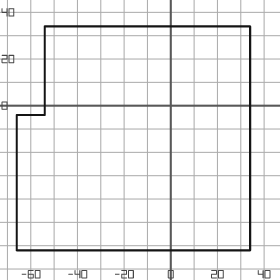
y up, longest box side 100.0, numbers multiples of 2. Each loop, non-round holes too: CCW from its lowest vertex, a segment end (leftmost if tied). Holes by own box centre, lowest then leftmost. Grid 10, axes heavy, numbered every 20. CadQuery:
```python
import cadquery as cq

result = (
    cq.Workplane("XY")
    .moveTo(-66.0, -62.0)
    .lineTo(34.0, -62.0)
    .lineTo(34.0, 34.0)
    .lineTo(-54.0, 34.0)
    .lineTo(-54.0, -4.0)
    .lineTo(-66.0, -4.0)
    .close()
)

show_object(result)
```